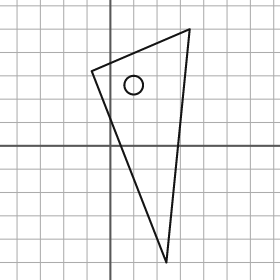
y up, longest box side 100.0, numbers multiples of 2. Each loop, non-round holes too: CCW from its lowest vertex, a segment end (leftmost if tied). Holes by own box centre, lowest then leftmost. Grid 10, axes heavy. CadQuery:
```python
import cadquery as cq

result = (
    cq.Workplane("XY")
    .moveTo(24.0, -50.0)
    .lineTo(34.0, 50.0)
    .lineTo(-8.0, 32.0)
    .close()
    .moveTo(10.0, 26.0)
    .circle(4.0)
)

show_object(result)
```